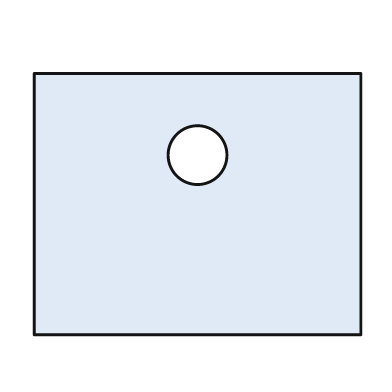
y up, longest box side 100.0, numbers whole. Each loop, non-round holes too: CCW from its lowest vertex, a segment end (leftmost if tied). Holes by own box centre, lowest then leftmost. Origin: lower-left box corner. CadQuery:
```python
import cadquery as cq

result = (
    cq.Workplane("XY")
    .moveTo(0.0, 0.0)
    .lineTo(100.0, 0.0)
    .lineTo(100.0, 80.0)
    .lineTo(0.0, 80.0)
    .close()
    .moveTo(50.0, 55.0)
    .circle(9.0)
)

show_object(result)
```